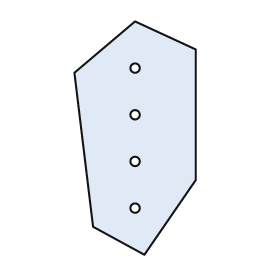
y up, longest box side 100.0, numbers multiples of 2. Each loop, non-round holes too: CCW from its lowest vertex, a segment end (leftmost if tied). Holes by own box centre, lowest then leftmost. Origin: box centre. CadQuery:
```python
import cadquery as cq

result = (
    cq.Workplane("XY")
    .moveTo(4.0, -50.0)
    .lineTo(26.0, -18.0)
    .lineTo(26.0, 38.0)
    .lineTo(0.0, 50.0)
    .lineTo(-26.0, 28.0)
    .lineTo(-18.0, -38.0)
    .close()
    .moveTo(0.0, -30.0)
    .circle(2.0)
    .moveTo(0.0, -10.0)
    .circle(2.0)
    .moveTo(0.0, 10.0)
    .circle(2.0)
    .moveTo(0.0, 30.0)
    .circle(2.0)
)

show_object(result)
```